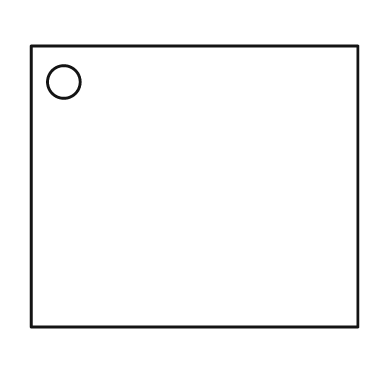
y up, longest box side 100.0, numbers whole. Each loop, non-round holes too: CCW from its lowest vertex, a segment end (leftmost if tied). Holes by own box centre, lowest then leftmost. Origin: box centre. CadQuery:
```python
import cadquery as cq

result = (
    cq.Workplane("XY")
    .moveTo(-50.0, -43.0)
    .lineTo(50.0, -43.0)
    .lineTo(50.0, 43.0)
    .lineTo(-50.0, 43.0)
    .close()
    .moveTo(-40.0, 32.0)
    .circle(5.0)
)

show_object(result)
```